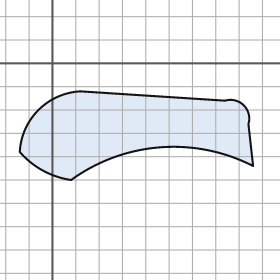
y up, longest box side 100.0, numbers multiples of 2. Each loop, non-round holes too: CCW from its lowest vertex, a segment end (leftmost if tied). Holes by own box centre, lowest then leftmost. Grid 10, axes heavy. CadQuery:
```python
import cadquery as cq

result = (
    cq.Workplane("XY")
    .moveTo(8.0, -50.0)
    .threePointArc((46.0, -36.0), (86.0, -44.0))
    .lineTo(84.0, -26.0)
    .threePointArc((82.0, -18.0), (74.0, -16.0))
    .lineTo(12.0, -12.0)
    .threePointArc((-6.0, -20.0), (-14.0, -38.0))
    .threePointArc((-4.0, -46.0), (8.0, -50.0))
    .close()
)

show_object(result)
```